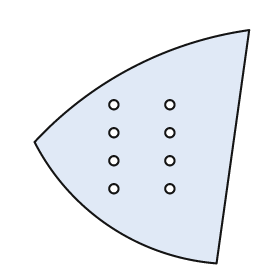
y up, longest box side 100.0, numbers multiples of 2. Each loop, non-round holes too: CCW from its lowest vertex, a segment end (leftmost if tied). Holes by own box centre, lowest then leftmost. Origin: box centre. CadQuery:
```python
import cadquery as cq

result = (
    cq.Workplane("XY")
    .moveTo(32.0, -50.0)
    .lineTo(46.0, 50.0)
    .threePointArc((-4.0, 34.0), (-46.0, 2.0))
    .threePointArc((-14.0, -34.0), (32.0, -50.0))
    .close()
    .moveTo(-12.0, -18.0)
    .circle(2.0)
    .moveTo(12.0, -18.0)
    .circle(2.0)
    .moveTo(-12.0, -6.0)
    .circle(2.0)
    .moveTo(12.0, -6.0)
    .circle(2.0)
    .moveTo(-12.0, 6.0)
    .circle(2.0)
    .moveTo(12.0, 6.0)
    .circle(2.0)
    .moveTo(-12.0, 18.0)
    .circle(2.0)
    .moveTo(12.0, 18.0)
    .circle(2.0)
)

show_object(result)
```